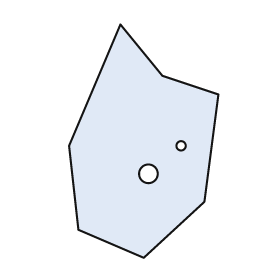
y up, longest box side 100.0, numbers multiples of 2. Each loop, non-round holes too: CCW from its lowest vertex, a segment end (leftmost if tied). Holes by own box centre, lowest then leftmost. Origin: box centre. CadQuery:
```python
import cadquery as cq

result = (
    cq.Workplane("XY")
    .moveTo(0.0, -50.0)
    .lineTo(26.0, -26.0)
    .lineTo(32.0, 20.0)
    .lineTo(8.0, 28.0)
    .lineTo(-10.0, 50.0)
    .lineTo(-32.0, -2.0)
    .lineTo(-28.0, -38.0)
    .close()
    .moveTo(2.0, -14.0)
    .circle(4.0)
    .moveTo(16.0, -2.0)
    .circle(2.0)
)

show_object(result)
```